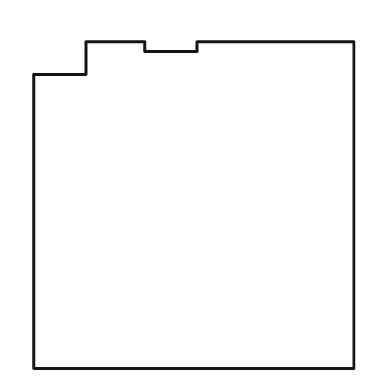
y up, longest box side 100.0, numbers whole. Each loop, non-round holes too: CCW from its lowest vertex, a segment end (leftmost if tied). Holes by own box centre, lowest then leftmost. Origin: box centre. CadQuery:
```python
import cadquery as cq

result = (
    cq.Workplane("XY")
    .moveTo(-49.0, -50.0)
    .lineTo(49.0, -50.0)
    .lineTo(49.0, 50.0)
    .lineTo(1.0, 50.0)
    .lineTo(1.0, 47.0)
    .lineTo(-15.0, 47.0)
    .lineTo(-15.0, 50.0)
    .lineTo(-33.0, 50.0)
    .lineTo(-33.0, 40.0)
    .lineTo(-49.0, 40.0)
    .close()
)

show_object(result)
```